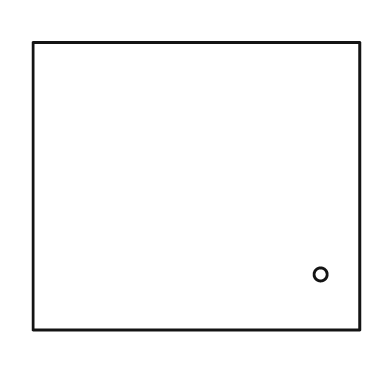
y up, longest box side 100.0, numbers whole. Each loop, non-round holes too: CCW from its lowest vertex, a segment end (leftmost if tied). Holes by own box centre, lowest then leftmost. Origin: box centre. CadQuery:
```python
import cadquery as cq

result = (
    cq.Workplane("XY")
    .moveTo(-50.0, -44.0)
    .lineTo(50.0, -44.0)
    .lineTo(50.0, 44.0)
    .lineTo(-50.0, 44.0)
    .close()
    .moveTo(38.0, -27.0)
    .circle(2.0)
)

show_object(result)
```